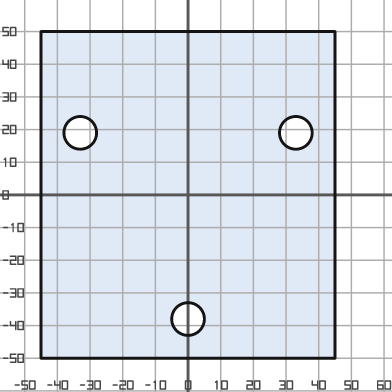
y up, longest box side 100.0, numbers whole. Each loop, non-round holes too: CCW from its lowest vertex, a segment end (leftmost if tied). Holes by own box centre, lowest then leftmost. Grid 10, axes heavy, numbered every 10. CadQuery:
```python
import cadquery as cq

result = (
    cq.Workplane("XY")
    .moveTo(-45.0, -50.0)
    .lineTo(45.0, -50.0)
    .lineTo(45.0, 50.0)
    .lineTo(-45.0, 50.0)
    .close()
    .moveTo(0.0, -38.0)
    .circle(5.0)
    .moveTo(-33.0, 19.0)
    .circle(5.0)
    .moveTo(33.0, 19.0)
    .circle(5.0)
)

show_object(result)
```